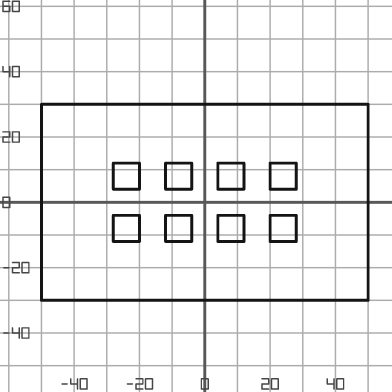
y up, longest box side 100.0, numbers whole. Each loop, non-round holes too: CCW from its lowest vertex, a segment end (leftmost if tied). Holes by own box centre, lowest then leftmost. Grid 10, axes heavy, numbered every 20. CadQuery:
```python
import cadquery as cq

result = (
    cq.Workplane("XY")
    .moveTo(-50.0, -30.0)
    .lineTo(50.0, -30.0)
    .lineTo(50.0, 30.0)
    .lineTo(-50.0, 30.0)
    .close()
    .moveTo(-28.0, -12.0)
    .lineTo(-20.0, -12.0)
    .lineTo(-20.0, -4.0)
    .lineTo(-28.0, -4.0)
    .close()
    .moveTo(-12.0, -12.0)
    .lineTo(-4.0, -12.0)
    .lineTo(-4.0, -4.0)
    .lineTo(-12.0, -4.0)
    .close()
    .moveTo(4.0, -12.0)
    .lineTo(12.0, -12.0)
    .lineTo(12.0, -4.0)
    .lineTo(4.0, -4.0)
    .close()
    .moveTo(20.0, -12.0)
    .lineTo(28.0, -12.0)
    .lineTo(28.0, -4.0)
    .lineTo(20.0, -4.0)
    .close()
    .moveTo(-28.0, 4.0)
    .lineTo(-20.0, 4.0)
    .lineTo(-20.0, 12.0)
    .lineTo(-28.0, 12.0)
    .close()
    .moveTo(-12.0, 4.0)
    .lineTo(-4.0, 4.0)
    .lineTo(-4.0, 12.0)
    .lineTo(-12.0, 12.0)
    .close()
    .moveTo(4.0, 4.0)
    .lineTo(12.0, 4.0)
    .lineTo(12.0, 12.0)
    .lineTo(4.0, 12.0)
    .close()
    .moveTo(20.0, 4.0)
    .lineTo(28.0, 4.0)
    .lineTo(28.0, 12.0)
    .lineTo(20.0, 12.0)
    .close()
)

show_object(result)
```